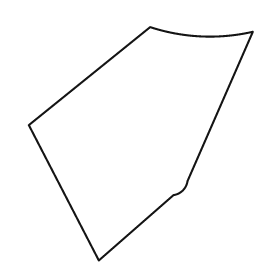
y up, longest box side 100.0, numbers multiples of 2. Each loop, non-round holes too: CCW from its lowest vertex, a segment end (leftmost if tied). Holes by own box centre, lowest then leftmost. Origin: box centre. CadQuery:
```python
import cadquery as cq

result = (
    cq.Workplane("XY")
    .moveTo(-18.0, -50.0)
    .lineTo(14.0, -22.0)
    .threePointArc((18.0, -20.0), (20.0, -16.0))
    .lineTo(48.0, 48.0)
    .threePointArc((26.0, 46.0), (4.0, 50.0))
    .lineTo(-48.0, 8.0)
    .close()
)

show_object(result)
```